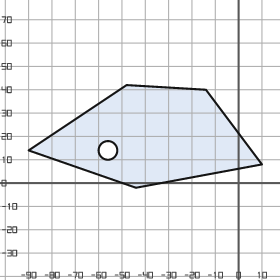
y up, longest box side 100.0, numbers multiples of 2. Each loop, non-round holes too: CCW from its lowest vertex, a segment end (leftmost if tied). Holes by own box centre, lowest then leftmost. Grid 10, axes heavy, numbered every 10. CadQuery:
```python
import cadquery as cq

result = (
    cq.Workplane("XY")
    .moveTo(-44.0, -2.0)
    .lineTo(10.0, 8.0)
    .lineTo(-14.0, 40.0)
    .lineTo(-48.0, 42.0)
    .lineTo(-90.0, 14.0)
    .close()
    .moveTo(-56.0, 14.0)
    .circle(4.0)
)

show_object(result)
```